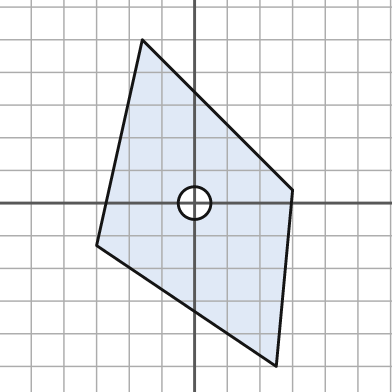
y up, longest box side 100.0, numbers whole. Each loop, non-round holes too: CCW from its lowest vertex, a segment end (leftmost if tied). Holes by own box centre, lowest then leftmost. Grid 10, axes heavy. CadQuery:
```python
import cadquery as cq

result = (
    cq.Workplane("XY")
    .moveTo(25.0, -50.0)
    .lineTo(30.0, 4.0)
    .lineTo(-16.0, 50.0)
    .lineTo(-30.0, -13.0)
    .close()
    .moveTo(0.0, 0.0)
    .circle(5.0)
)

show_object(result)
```